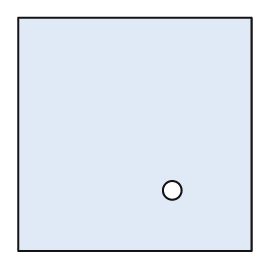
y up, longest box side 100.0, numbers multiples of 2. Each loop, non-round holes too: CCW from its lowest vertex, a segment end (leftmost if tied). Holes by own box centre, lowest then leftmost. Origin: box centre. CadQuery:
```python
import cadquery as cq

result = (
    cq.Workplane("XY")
    .moveTo(-50.0, -50.0)
    .lineTo(50.0, -50.0)
    .lineTo(50.0, 50.0)
    .lineTo(-50.0, 50.0)
    .close()
    .moveTo(16.0, -24.0)
    .circle(4.0)
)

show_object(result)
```